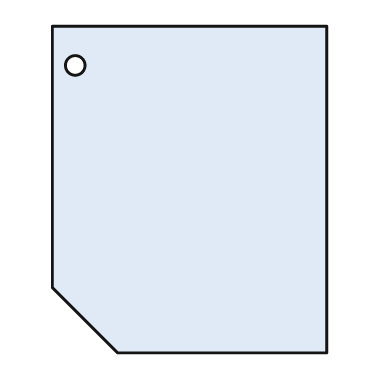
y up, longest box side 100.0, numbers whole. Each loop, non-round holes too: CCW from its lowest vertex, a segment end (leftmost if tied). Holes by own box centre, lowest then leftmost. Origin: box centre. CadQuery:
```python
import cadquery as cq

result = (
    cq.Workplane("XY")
    .moveTo(-22.0, -50.0)
    .lineTo(42.0, -50.0)
    .lineTo(42.0, 50.0)
    .lineTo(-42.0, 50.0)
    .lineTo(-42.0, -30.0)
    .close()
    .moveTo(-35.0, 38.0)
    .circle(3.0)
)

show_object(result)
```